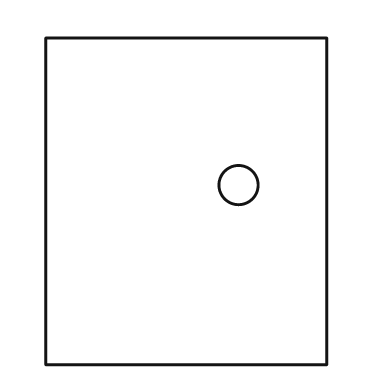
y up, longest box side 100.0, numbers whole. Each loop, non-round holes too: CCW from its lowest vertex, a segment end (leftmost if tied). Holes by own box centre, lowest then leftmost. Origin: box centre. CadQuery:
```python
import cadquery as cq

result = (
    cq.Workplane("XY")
    .moveTo(-43.0, -50.0)
    .lineTo(43.0, -50.0)
    .lineTo(43.0, 50.0)
    .lineTo(-43.0, 50.0)
    .close()
    .moveTo(16.0, 5.0)
    .circle(6.0)
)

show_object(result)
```